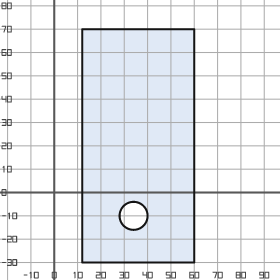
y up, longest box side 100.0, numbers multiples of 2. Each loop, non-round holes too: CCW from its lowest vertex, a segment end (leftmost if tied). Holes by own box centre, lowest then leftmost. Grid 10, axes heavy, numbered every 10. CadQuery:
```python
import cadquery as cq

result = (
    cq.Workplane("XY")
    .moveTo(12.0, -30.0)
    .lineTo(60.0, -30.0)
    .lineTo(60.0, 70.0)
    .lineTo(12.0, 70.0)
    .close()
    .moveTo(34.0, -10.0)
    .circle(6.0)
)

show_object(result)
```